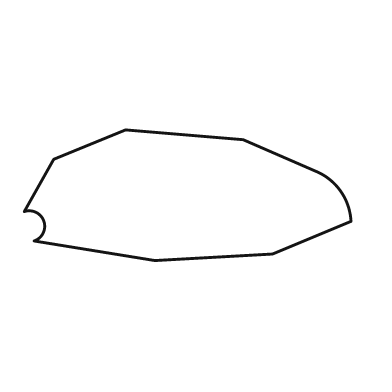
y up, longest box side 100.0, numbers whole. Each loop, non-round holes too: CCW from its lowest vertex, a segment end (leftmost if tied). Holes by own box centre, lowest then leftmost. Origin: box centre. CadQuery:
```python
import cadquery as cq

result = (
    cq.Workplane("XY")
    .moveTo(-10.0, -20.0)
    .lineTo(26.0, -18.0)
    .lineTo(50.0, -8.0)
    .threePointArc((47.0, 1.0), (40.0, 7.0))
    .lineTo(17.0, 17.0)
    .lineTo(-19.0, 20.0)
    .lineTo(-41.0, 11.0)
    .lineTo(-50.0, -5.0)
    .threePointArc((-44.0, -8.0), (-47.0, -14.0))
    .close()
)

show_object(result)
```